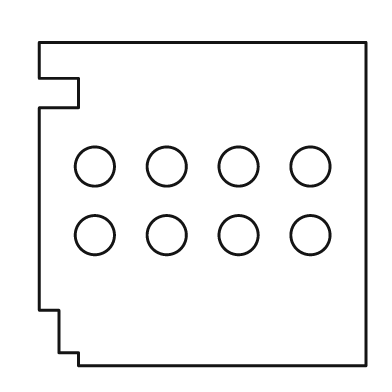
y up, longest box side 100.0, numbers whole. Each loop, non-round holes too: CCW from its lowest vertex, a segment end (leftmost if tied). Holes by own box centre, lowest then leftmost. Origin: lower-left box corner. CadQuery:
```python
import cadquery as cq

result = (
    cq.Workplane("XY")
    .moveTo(12.0, 0.0)
    .lineTo(100.0, 0.0)
    .lineTo(100.0, 99.0)
    .lineTo(0.0, 99.0)
    .lineTo(0.0, 88.0)
    .lineTo(12.0, 88.0)
    .lineTo(12.0, 79.0)
    .lineTo(0.0, 79.0)
    .lineTo(0.0, 17.0)
    .lineTo(6.0, 17.0)
    .lineTo(6.0, 4.0)
    .lineTo(12.0, 4.0)
    .close()
    .moveTo(17.0, 40.0)
    .circle(6.0)
    .moveTo(39.0, 40.0)
    .circle(6.0)
    .moveTo(61.0, 40.0)
    .circle(6.0)
    .moveTo(83.0, 40.0)
    .circle(6.0)
    .moveTo(17.0, 61.0)
    .circle(6.0)
    .moveTo(39.0, 61.0)
    .circle(6.0)
    .moveTo(61.0, 61.0)
    .circle(6.0)
    .moveTo(83.0, 61.0)
    .circle(6.0)
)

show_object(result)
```